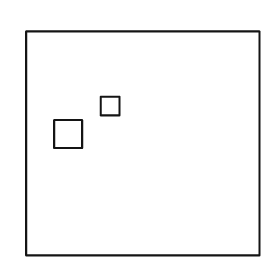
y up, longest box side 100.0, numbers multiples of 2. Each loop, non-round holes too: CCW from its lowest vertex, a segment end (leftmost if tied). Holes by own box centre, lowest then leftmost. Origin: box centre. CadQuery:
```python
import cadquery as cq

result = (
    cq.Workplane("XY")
    .moveTo(-50.0, -48.0)
    .lineTo(50.0, -48.0)
    .lineTo(50.0, 48.0)
    .lineTo(-50.0, 48.0)
    .close()
    .moveTo(-38.0, -2.0)
    .lineTo(-26.0, -2.0)
    .lineTo(-26.0, 10.0)
    .lineTo(-38.0, 10.0)
    .close()
    .moveTo(-18.0, 12.0)
    .lineTo(-10.0, 12.0)
    .lineTo(-10.0, 20.0)
    .lineTo(-18.0, 20.0)
    .close()
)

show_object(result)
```